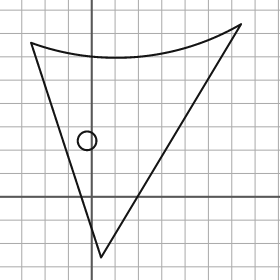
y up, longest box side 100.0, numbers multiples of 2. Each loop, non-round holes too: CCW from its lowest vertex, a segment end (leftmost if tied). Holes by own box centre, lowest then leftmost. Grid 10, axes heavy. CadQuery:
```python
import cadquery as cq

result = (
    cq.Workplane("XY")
    .moveTo(4.0, -26.0)
    .lineTo(64.0, 74.0)
    .threePointArc((20.0, 60.0), (-26.0, 66.0))
    .close()
    .moveTo(-2.0, 24.0)
    .circle(4.0)
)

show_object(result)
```